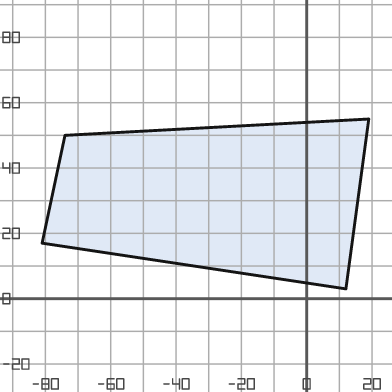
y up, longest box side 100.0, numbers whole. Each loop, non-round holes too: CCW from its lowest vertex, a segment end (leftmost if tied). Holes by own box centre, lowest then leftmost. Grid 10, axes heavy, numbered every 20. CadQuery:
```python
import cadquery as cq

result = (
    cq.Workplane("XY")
    .moveTo(12.0, 3.0)
    .lineTo(19.0, 55.0)
    .lineTo(-74.0, 50.0)
    .lineTo(-81.0, 17.0)
    .close()
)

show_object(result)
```